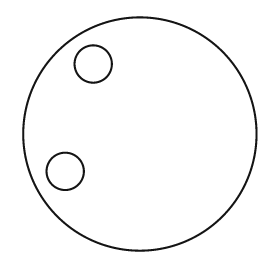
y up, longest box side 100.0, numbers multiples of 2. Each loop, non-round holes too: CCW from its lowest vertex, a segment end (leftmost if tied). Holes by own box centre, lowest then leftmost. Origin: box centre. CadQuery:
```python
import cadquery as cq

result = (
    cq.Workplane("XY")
    .moveTo(0.0, 0.0)
    .circle(50.0)
    .moveTo(-32.0, -16.0)
    .circle(8.0)
    .moveTo(-20.0, 30.0)
    .circle(8.0)
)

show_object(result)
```